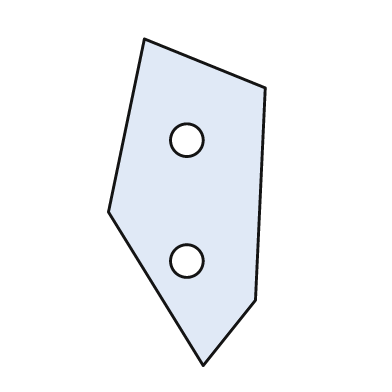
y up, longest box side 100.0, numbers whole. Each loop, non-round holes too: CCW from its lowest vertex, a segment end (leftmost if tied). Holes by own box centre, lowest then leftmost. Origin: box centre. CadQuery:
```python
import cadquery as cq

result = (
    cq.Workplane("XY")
    .moveTo(5.0, -50.0)
    .lineTo(21.0, -30.0)
    .lineTo(24.0, 35.0)
    .lineTo(-13.0, 50.0)
    .lineTo(-24.0, -3.0)
    .close()
    .moveTo(0.0, -18.0)
    .circle(5.0)
    .moveTo(0.0, 19.0)
    .circle(5.0)
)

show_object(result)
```